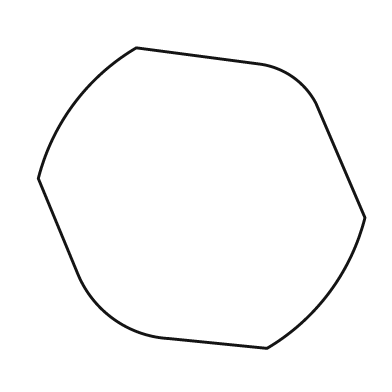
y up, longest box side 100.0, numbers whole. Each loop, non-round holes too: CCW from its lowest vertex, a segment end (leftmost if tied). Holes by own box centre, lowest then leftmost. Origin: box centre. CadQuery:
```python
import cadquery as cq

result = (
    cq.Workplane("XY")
    .moveTo(20.0, -46.0)
    .threePointArc((39.0, -29.0), (50.0, -6.0))
    .lineTo(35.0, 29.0)
    .threePointArc((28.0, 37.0), (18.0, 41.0))
    .lineTo(-20.0, 46.0)
    .threePointArc((-39.0, 29.0), (-50.0, 6.0))
    .lineTo(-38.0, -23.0)
    .threePointArc((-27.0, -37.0), (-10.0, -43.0))
    .close()
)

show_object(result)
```